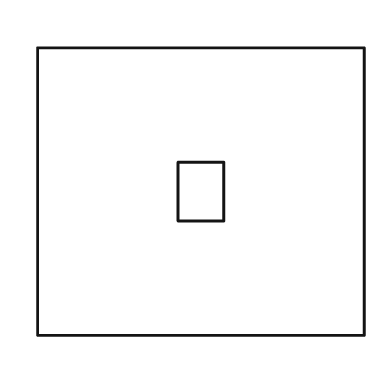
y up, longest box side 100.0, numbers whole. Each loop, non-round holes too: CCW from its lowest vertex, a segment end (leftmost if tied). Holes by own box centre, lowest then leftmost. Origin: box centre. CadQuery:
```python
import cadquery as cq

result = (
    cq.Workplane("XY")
    .moveTo(-50.0, -44.0)
    .lineTo(50.0, -44.0)
    .lineTo(50.0, 44.0)
    .lineTo(-50.0, 44.0)
    .close()
    .moveTo(-7.0, -9.0)
    .lineTo(7.0, -9.0)
    .lineTo(7.0, 9.0)
    .lineTo(-7.0, 9.0)
    .close()
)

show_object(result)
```